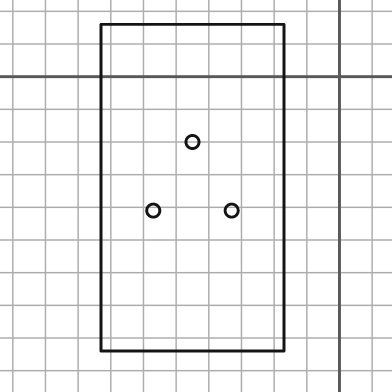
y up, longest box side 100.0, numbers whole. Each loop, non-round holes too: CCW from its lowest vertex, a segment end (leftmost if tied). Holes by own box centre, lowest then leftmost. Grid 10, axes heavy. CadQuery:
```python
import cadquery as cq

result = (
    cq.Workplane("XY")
    .moveTo(-73.0, -84.0)
    .lineTo(-17.0, -84.0)
    .lineTo(-17.0, 16.0)
    .lineTo(-73.0, 16.0)
    .close()
    .moveTo(-57.0, -41.0)
    .circle(2.0)
    .moveTo(-33.0, -41.0)
    .circle(2.0)
    .moveTo(-45.0, -20.0)
    .circle(2.0)
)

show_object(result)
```